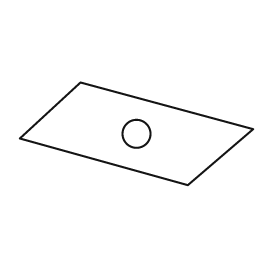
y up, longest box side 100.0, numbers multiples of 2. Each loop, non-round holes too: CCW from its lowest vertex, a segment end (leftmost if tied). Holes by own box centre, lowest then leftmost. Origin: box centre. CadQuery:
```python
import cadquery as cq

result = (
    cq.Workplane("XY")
    .moveTo(22.0, -22.0)
    .lineTo(50.0, 2.0)
    .lineTo(-24.0, 22.0)
    .lineTo(-50.0, -2.0)
    .close()
    .moveTo(0.0, 0.0)
    .circle(6.0)
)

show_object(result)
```